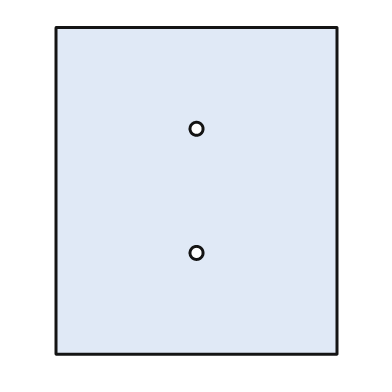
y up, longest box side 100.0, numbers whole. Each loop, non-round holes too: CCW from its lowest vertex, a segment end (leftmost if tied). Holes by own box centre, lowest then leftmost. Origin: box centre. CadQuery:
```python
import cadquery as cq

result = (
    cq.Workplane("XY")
    .moveTo(-43.0, -50.0)
    .lineTo(43.0, -50.0)
    .lineTo(43.0, 50.0)
    .lineTo(-43.0, 50.0)
    .close()
    .moveTo(0.0, -19.0)
    .circle(2.0)
    .moveTo(0.0, 19.0)
    .circle(2.0)
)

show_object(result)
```